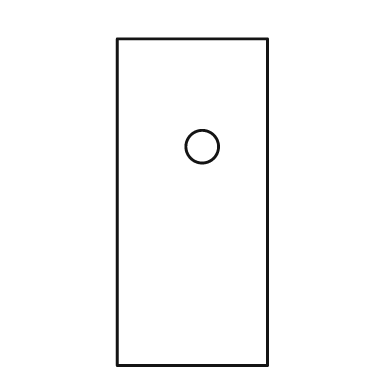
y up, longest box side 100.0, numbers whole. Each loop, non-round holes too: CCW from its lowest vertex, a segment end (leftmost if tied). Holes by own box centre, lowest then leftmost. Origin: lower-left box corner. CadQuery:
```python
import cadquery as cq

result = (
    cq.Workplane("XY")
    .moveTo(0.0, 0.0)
    .lineTo(46.0, 0.0)
    .lineTo(46.0, 100.0)
    .lineTo(0.0, 100.0)
    .close()
    .moveTo(26.0, 67.0)
    .circle(5.0)
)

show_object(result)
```